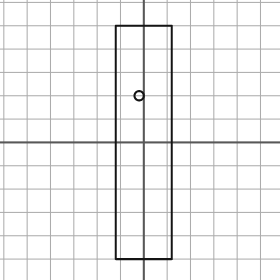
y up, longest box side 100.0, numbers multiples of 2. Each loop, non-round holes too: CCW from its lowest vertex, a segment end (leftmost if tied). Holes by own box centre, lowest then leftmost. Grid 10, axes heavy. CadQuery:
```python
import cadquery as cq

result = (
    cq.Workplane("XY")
    .moveTo(-12.0, -50.0)
    .lineTo(12.0, -50.0)
    .lineTo(12.0, 50.0)
    .lineTo(-12.0, 50.0)
    .close()
    .moveTo(-2.0, 20.0)
    .circle(2.0)
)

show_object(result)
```